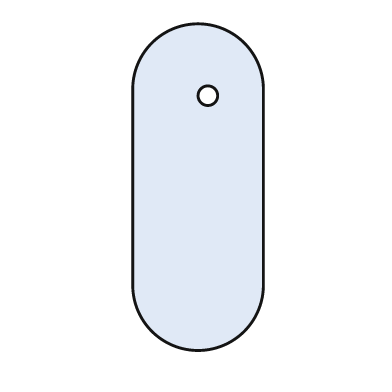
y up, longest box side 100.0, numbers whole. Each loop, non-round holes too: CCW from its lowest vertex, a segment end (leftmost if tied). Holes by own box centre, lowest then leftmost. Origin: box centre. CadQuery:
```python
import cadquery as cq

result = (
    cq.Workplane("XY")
    .moveTo(-20.0, -30.0)
    .threePointArc((0.0, -50.0), (20.0, -30.0))
    .lineTo(20.0, 30.0)
    .threePointArc((0.0, 50.0), (-20.0, 30.0))
    .close()
    .moveTo(3.0, 28.0)
    .circle(3.0)
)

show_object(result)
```